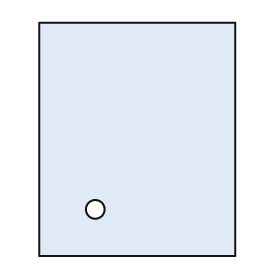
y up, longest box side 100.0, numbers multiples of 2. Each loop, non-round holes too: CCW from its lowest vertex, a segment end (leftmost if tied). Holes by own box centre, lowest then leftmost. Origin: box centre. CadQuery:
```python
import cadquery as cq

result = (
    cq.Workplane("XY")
    .moveTo(-42.0, -50.0)
    .lineTo(42.0, -50.0)
    .lineTo(42.0, 50.0)
    .lineTo(-42.0, 50.0)
    .close()
    .moveTo(-18.0, -30.0)
    .circle(4.0)
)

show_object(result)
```